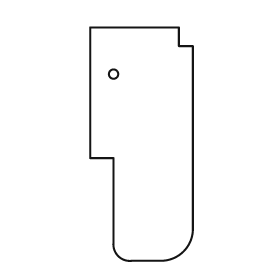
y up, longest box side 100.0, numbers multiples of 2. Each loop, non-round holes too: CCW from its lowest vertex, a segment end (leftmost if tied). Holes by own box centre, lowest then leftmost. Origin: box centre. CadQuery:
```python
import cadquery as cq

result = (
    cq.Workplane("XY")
    .moveTo(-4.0, -50.0)
    .lineTo(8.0, -50.0)
    .threePointArc((18.0, -46.0), (22.0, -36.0))
    .lineTo(22.0, 42.0)
    .lineTo(16.0, 42.0)
    .lineTo(16.0, 50.0)
    .lineTo(-22.0, 50.0)
    .lineTo(-22.0, -6.0)
    .lineTo(-12.0, -6.0)
    .lineTo(-12.0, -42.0)
    .threePointArc((-10.0, -48.0), (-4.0, -50.0))
    .close()
    .moveTo(-12.0, 30.0)
    .circle(2.0)
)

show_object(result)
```